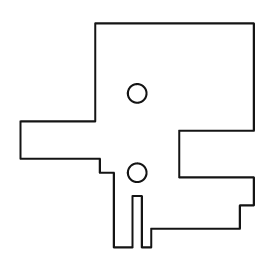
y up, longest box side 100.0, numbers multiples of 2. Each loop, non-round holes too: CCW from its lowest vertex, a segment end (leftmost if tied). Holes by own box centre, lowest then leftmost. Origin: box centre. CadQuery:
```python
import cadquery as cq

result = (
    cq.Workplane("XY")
    .moveTo(-10.0, -48.0)
    .lineTo(-2.0, -48.0)
    .lineTo(-2.0, -26.0)
    .lineTo(2.0, -26.0)
    .lineTo(2.0, -48.0)
    .lineTo(6.0, -48.0)
    .lineTo(6.0, -40.0)
    .lineTo(44.0, -40.0)
    .lineTo(44.0, -30.0)
    .lineTo(50.0, -30.0)
    .lineTo(50.0, -18.0)
    .lineTo(18.0, -18.0)
    .lineTo(18.0, 2.0)
    .lineTo(50.0, 2.0)
    .lineTo(50.0, 48.0)
    .lineTo(-18.0, 48.0)
    .lineTo(-18.0, 6.0)
    .lineTo(-50.0, 6.0)
    .lineTo(-50.0, -10.0)
    .lineTo(-16.0, -10.0)
    .lineTo(-16.0, -16.0)
    .lineTo(-10.0, -16.0)
    .close()
    .moveTo(0.0, -16.0)
    .circle(4.0)
    .moveTo(0.0, 18.0)
    .circle(4.0)
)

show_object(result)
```